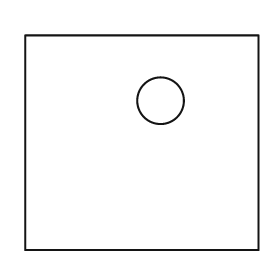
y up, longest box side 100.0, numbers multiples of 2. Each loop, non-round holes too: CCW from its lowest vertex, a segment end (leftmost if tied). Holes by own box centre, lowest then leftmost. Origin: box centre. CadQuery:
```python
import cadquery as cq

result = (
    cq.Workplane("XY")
    .moveTo(-50.0, -46.0)
    .lineTo(50.0, -46.0)
    .lineTo(50.0, 46.0)
    .lineTo(-50.0, 46.0)
    .close()
    .moveTo(8.0, 18.0)
    .circle(10.0)
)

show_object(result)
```